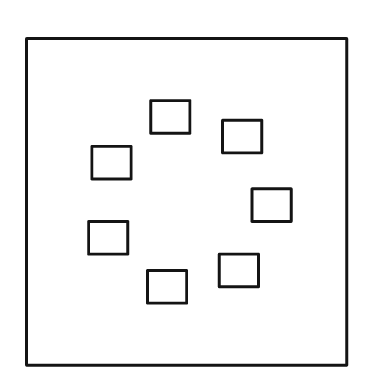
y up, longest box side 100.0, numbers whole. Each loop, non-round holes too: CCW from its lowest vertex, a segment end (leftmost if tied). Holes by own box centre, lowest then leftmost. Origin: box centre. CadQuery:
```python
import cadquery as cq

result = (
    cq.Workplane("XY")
    .moveTo(-49.0, -50.0)
    .lineTo(49.0, -50.0)
    .lineTo(49.0, 50.0)
    .lineTo(-49.0, 50.0)
    .close()
    .moveTo(-12.0, -31.0)
    .lineTo(0.0, -31.0)
    .lineTo(0.0, -21.0)
    .lineTo(-12.0, -21.0)
    .close()
    .moveTo(10.0, -26.0)
    .lineTo(22.0, -26.0)
    .lineTo(22.0, -16.0)
    .lineTo(10.0, -16.0)
    .close()
    .moveTo(-30.0, -16.0)
    .lineTo(-18.0, -16.0)
    .lineTo(-18.0, -6.0)
    .lineTo(-30.0, -6.0)
    .close()
    .moveTo(20.0, -6.0)
    .lineTo(32.0, -6.0)
    .lineTo(32.0, 4.0)
    .lineTo(20.0, 4.0)
    .close()
    .moveTo(-29.0, 7.0)
    .lineTo(-17.0, 7.0)
    .lineTo(-17.0, 17.0)
    .lineTo(-29.0, 17.0)
    .close()
    .moveTo(11.0, 15.0)
    .lineTo(23.0, 15.0)
    .lineTo(23.0, 25.0)
    .lineTo(11.0, 25.0)
    .close()
    .moveTo(-11.0, 21.0)
    .lineTo(1.0, 21.0)
    .lineTo(1.0, 31.0)
    .lineTo(-11.0, 31.0)
    .close()
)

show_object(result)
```